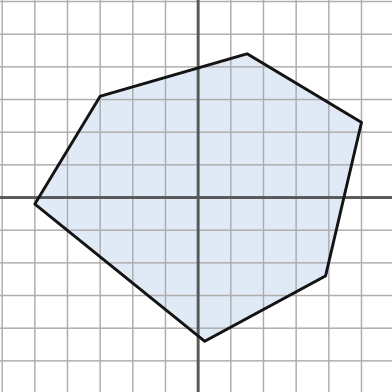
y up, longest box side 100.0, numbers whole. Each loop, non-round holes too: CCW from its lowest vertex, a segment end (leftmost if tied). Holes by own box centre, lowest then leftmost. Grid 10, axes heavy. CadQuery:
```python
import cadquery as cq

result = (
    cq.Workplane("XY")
    .moveTo(2.0, -44.0)
    .lineTo(39.0, -24.0)
    .lineTo(50.0, 23.0)
    .lineTo(15.0, 44.0)
    .lineTo(-30.0, 31.0)
    .lineTo(-50.0, -2.0)
    .close()
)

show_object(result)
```